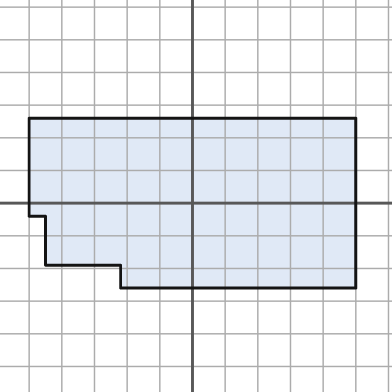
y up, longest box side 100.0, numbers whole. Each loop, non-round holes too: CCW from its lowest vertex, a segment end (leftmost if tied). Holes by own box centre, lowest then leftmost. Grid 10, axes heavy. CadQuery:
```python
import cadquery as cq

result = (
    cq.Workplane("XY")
    .moveTo(-22.0, -26.0)
    .lineTo(50.0, -26.0)
    .lineTo(50.0, 26.0)
    .lineTo(-50.0, 26.0)
    .lineTo(-50.0, -4.0)
    .lineTo(-45.0, -4.0)
    .lineTo(-45.0, -19.0)
    .lineTo(-22.0, -19.0)
    .close()
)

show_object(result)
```